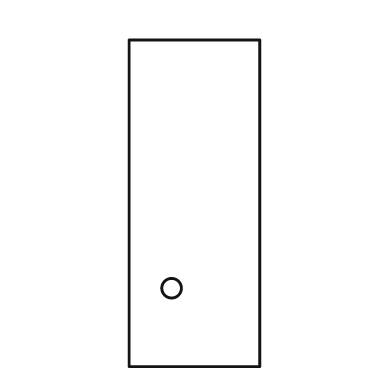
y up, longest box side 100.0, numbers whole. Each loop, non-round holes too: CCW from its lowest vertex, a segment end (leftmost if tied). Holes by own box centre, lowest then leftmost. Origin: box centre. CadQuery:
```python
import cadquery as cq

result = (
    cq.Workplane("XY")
    .moveTo(-20.0, -50.0)
    .lineTo(20.0, -50.0)
    .lineTo(20.0, 50.0)
    .lineTo(-20.0, 50.0)
    .close()
    .moveTo(-7.0, -26.0)
    .circle(3.0)
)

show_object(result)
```